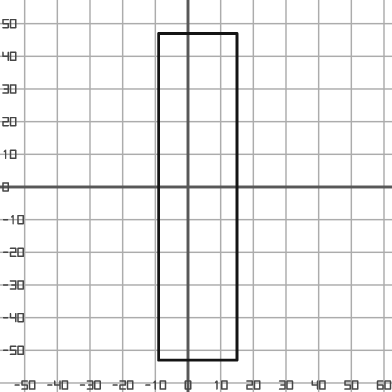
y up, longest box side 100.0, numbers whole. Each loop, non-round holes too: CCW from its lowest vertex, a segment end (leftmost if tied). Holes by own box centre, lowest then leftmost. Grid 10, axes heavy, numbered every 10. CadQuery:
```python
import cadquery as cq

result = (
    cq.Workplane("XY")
    .moveTo(-9.0, -53.0)
    .lineTo(15.0, -53.0)
    .lineTo(15.0, 47.0)
    .lineTo(-9.0, 47.0)
    .close()
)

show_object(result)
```